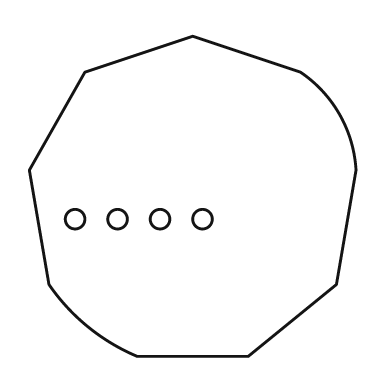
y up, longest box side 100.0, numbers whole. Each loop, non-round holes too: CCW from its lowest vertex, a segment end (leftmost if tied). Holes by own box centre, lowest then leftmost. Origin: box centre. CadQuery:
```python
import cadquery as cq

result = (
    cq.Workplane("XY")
    .moveTo(-17.0, -49.0)
    .lineTo(17.0, -49.0)
    .lineTo(44.0, -27.0)
    .lineTo(50.0, 8.0)
    .threePointArc((45.0, 25.0), (33.0, 38.0))
    .lineTo(0.0, 49.0)
    .lineTo(-33.0, 38.0)
    .lineTo(-50.0, 8.0)
    .lineTo(-44.0, -27.0)
    .threePointArc((-32.0, -40.0), (-17.0, -49.0))
    .close()
    .moveTo(-36.0, -7.0)
    .circle(3.0)
    .moveTo(-23.0, -7.0)
    .circle(3.0)
    .moveTo(-10.0, -7.0)
    .circle(3.0)
    .moveTo(3.0, -7.0)
    .circle(3.0)
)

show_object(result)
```